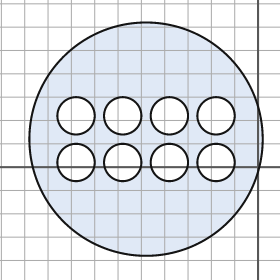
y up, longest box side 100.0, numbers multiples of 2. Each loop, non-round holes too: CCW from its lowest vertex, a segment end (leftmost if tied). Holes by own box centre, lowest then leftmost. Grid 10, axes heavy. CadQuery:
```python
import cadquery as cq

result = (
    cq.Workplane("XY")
    .moveTo(-48.0, 12.0)
    .circle(50.0)
    .moveTo(-78.0, 2.0)
    .circle(8.0)
    .moveTo(-58.0, 2.0)
    .circle(8.0)
    .moveTo(-38.0, 2.0)
    .circle(8.0)
    .moveTo(-18.0, 2.0)
    .circle(8.0)
    .moveTo(-78.0, 22.0)
    .circle(8.0)
    .moveTo(-58.0, 22.0)
    .circle(8.0)
    .moveTo(-38.0, 22.0)
    .circle(8.0)
    .moveTo(-18.0, 22.0)
    .circle(8.0)
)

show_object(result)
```